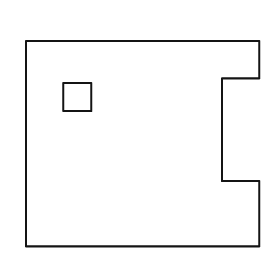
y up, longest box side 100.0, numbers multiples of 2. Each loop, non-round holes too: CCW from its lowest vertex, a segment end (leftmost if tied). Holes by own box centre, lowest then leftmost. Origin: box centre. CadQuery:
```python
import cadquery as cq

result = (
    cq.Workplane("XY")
    .moveTo(-50.0, -44.0)
    .lineTo(50.0, -44.0)
    .lineTo(50.0, -16.0)
    .lineTo(34.0, -16.0)
    .lineTo(34.0, 28.0)
    .lineTo(50.0, 28.0)
    .lineTo(50.0, 44.0)
    .lineTo(-50.0, 44.0)
    .close()
    .moveTo(-34.0, 14.0)
    .lineTo(-22.0, 14.0)
    .lineTo(-22.0, 26.0)
    .lineTo(-34.0, 26.0)
    .close()
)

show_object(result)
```